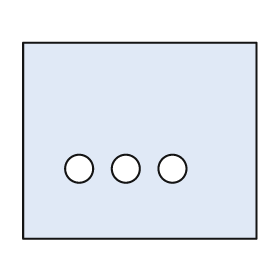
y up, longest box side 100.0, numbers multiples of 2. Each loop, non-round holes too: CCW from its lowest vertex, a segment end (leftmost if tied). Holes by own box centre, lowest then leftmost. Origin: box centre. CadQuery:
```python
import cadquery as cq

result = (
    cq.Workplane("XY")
    .moveTo(-50.0, -42.0)
    .lineTo(50.0, -42.0)
    .lineTo(50.0, 42.0)
    .lineTo(-50.0, 42.0)
    .close()
    .moveTo(-26.0, -12.0)
    .circle(6.0)
    .moveTo(-6.0, -12.0)
    .circle(6.0)
    .moveTo(14.0, -12.0)
    .circle(6.0)
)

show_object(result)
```